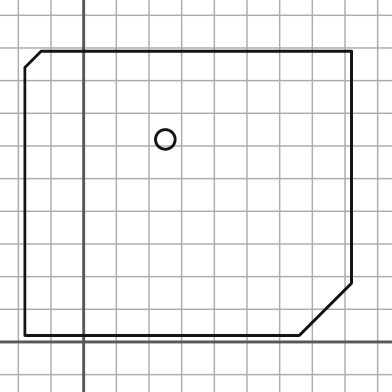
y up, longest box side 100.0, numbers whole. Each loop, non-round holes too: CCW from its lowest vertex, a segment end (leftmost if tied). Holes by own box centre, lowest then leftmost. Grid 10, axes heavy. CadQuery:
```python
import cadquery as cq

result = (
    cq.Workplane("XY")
    .moveTo(-18.0, 2.0)
    .lineTo(66.0, 2.0)
    .lineTo(82.0, 18.0)
    .lineTo(82.0, 89.0)
    .lineTo(-13.0, 89.0)
    .lineTo(-18.0, 84.0)
    .close()
    .moveTo(25.0, 62.0)
    .circle(3.0)
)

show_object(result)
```